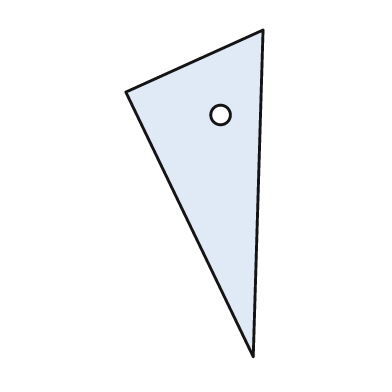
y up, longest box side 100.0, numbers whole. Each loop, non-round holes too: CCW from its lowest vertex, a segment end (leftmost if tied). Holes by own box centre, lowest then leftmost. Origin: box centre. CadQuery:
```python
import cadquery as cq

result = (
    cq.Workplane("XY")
    .moveTo(18.0, -50.0)
    .lineTo(21.0, 50.0)
    .lineTo(-21.0, 31.0)
    .close()
    .moveTo(8.0, 24.0)
    .circle(3.0)
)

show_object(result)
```